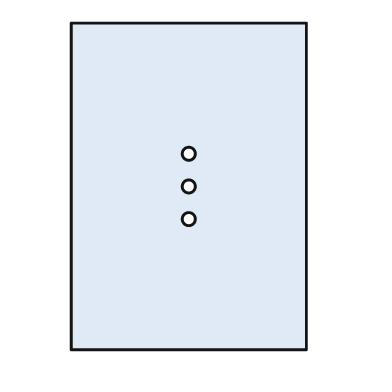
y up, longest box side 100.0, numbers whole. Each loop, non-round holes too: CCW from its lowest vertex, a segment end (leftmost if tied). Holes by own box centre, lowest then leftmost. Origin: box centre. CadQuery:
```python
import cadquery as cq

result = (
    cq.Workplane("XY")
    .moveTo(-36.0, -50.0)
    .lineTo(36.0, -50.0)
    .lineTo(36.0, 50.0)
    .lineTo(-36.0, 50.0)
    .close()
    .moveTo(0.0, -10.0)
    .circle(2.0)
    .moveTo(0.0, 0.0)
    .circle(2.0)
    .moveTo(0.0, 10.0)
    .circle(2.0)
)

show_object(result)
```